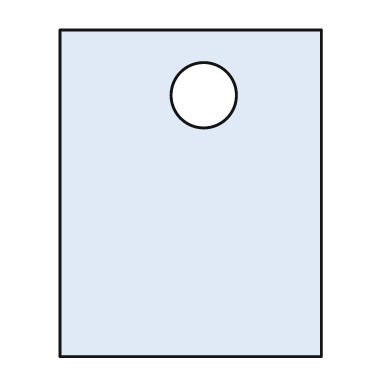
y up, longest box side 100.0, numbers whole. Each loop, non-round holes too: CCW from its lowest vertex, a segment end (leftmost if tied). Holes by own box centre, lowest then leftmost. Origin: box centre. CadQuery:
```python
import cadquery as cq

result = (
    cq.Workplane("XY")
    .moveTo(-40.0, -50.0)
    .lineTo(40.0, -50.0)
    .lineTo(40.0, 50.0)
    .lineTo(-40.0, 50.0)
    .close()
    .moveTo(4.0, 30.0)
    .circle(10.0)
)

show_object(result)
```